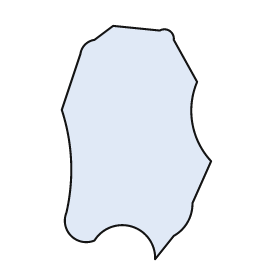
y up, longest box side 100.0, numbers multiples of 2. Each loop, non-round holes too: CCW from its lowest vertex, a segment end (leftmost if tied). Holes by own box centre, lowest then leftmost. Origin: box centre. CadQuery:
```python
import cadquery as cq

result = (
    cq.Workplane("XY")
    .moveTo(8.0, -50.0)
    .lineTo(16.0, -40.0)
    .threePointArc((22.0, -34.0), (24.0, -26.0))
    .lineTo(32.0, -8.0)
    .threePointArc((24.0, 8.0), (26.0, 26.0))
    .lineTo(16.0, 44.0)
    .threePointArc((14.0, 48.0), (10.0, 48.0))
    .lineTo(-10.0, 50.0)
    .lineTo(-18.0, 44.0)
    .threePointArc((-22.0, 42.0), (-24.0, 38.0))
    .lineTo(-32.0, 14.0)
    .threePointArc((-28.0, -8.0), (-30.0, -30.0))
    .threePointArc((-28.0, -40.0), (-18.0, -42.0))
    .threePointArc((-2.0, -36.0), (8.0, -50.0))
    .close()
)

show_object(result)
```